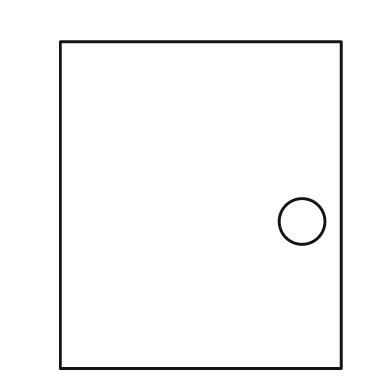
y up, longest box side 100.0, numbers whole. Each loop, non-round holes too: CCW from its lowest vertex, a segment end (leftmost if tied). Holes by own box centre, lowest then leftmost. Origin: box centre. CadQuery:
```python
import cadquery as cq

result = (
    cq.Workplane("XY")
    .moveTo(-43.0, -50.0)
    .lineTo(43.0, -50.0)
    .lineTo(43.0, 50.0)
    .lineTo(-43.0, 50.0)
    .close()
    .moveTo(31.0, -5.0)
    .circle(7.0)
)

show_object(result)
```